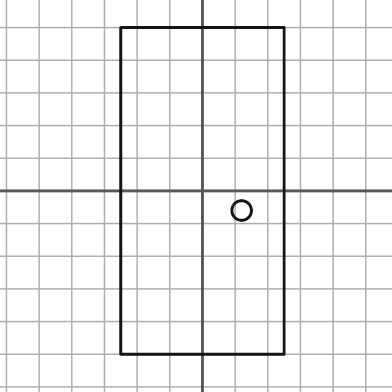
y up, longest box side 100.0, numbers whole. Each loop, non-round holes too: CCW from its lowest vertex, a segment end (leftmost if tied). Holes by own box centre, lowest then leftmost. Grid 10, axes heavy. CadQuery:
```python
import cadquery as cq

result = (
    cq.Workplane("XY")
    .moveTo(-25.0, -50.0)
    .lineTo(25.0, -50.0)
    .lineTo(25.0, 50.0)
    .lineTo(-25.0, 50.0)
    .close()
    .moveTo(12.0, -6.0)
    .circle(3.0)
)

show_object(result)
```